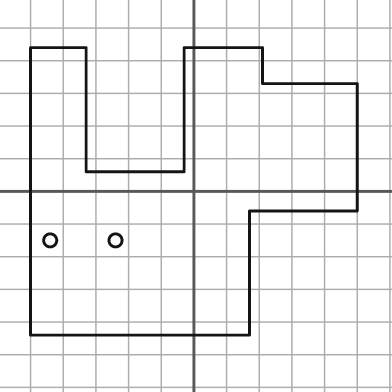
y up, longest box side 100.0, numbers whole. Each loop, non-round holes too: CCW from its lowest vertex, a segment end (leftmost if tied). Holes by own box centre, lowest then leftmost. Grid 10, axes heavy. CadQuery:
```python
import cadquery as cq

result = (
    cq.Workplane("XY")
    .moveTo(-50.0, -44.0)
    .lineTo(17.0, -44.0)
    .lineTo(17.0, -6.0)
    .lineTo(50.0, -6.0)
    .lineTo(50.0, 33.0)
    .lineTo(21.0, 33.0)
    .lineTo(21.0, 44.0)
    .lineTo(-3.0, 44.0)
    .lineTo(-3.0, 6.0)
    .lineTo(-33.0, 6.0)
    .lineTo(-33.0, 44.0)
    .lineTo(-50.0, 44.0)
    .close()
    .moveTo(-44.0, -15.0)
    .circle(2.0)
    .moveTo(-24.0, -15.0)
    .circle(2.0)
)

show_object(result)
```